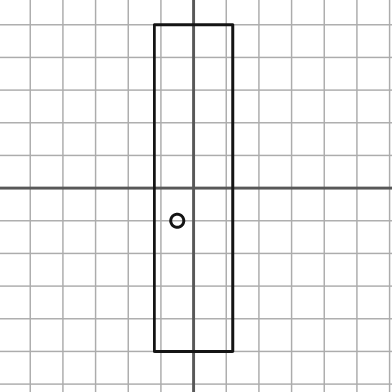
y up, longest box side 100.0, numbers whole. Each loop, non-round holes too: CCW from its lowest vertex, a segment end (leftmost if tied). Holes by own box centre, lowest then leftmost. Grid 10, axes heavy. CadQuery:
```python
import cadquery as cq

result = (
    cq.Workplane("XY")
    .moveTo(-12.0, -50.0)
    .lineTo(12.0, -50.0)
    .lineTo(12.0, 50.0)
    .lineTo(-12.0, 50.0)
    .close()
    .moveTo(-5.0, -10.0)
    .circle(2.0)
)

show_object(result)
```